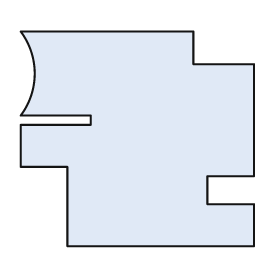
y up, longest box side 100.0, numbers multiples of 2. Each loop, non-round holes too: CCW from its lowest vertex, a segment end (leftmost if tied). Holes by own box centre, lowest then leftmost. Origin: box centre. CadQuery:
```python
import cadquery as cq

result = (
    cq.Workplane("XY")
    .moveTo(-30.0, -46.0)
    .lineTo(50.0, -46.0)
    .lineTo(50.0, -28.0)
    .lineTo(30.0, -28.0)
    .lineTo(30.0, -16.0)
    .lineTo(50.0, -16.0)
    .lineTo(50.0, 32.0)
    .lineTo(24.0, 32.0)
    .lineTo(24.0, 46.0)
    .lineTo(-50.0, 46.0)
    .threePointArc((-44.0, 28.0), (-50.0, 10.0))
    .lineTo(-20.0, 10.0)
    .lineTo(-20.0, 6.0)
    .lineTo(-50.0, 6.0)
    .lineTo(-50.0, -12.0)
    .lineTo(-30.0, -12.0)
    .close()
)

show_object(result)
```